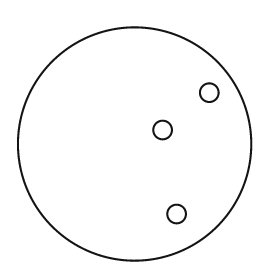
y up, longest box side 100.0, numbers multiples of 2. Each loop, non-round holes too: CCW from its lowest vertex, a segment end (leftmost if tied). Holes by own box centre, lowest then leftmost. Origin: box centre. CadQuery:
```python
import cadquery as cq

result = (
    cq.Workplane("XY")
    .moveTo(0.0, 0.0)
    .circle(50.0)
    .moveTo(18.0, -30.0)
    .circle(4.0)
    .moveTo(12.0, 6.0)
    .circle(4.0)
    .moveTo(32.0, 22.0)
    .circle(4.0)
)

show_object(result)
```